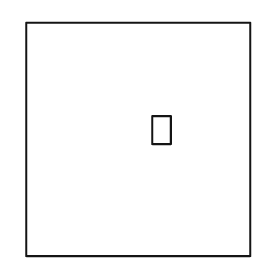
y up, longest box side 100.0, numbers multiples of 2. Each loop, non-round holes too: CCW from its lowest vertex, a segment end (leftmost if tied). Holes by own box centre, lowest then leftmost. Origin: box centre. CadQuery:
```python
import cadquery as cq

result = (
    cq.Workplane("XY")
    .moveTo(-48.0, -50.0)
    .lineTo(48.0, -50.0)
    .lineTo(48.0, 50.0)
    .lineTo(-48.0, 50.0)
    .close()
    .moveTo(6.0, -2.0)
    .lineTo(14.0, -2.0)
    .lineTo(14.0, 10.0)
    .lineTo(6.0, 10.0)
    .close()
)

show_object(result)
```